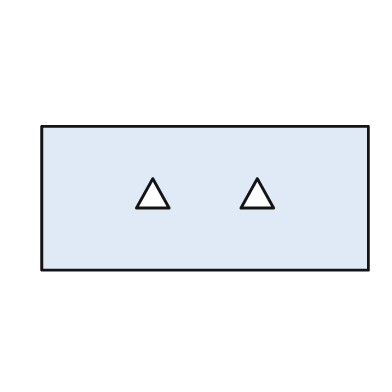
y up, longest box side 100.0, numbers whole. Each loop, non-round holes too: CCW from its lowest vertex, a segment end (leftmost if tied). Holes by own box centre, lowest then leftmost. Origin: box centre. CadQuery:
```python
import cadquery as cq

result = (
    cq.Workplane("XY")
    .moveTo(-50.0, -22.0)
    .lineTo(50.0, -22.0)
    .lineTo(50.0, 22.0)
    .lineTo(-50.0, 22.0)
    .close()
    .moveTo(-21.0, -3.0)
    .lineTo(-11.0, -3.0)
    .lineTo(-16.0, 6.0)
    .close()
    .moveTo(11.0, -3.0)
    .lineTo(21.0, -3.0)
    .lineTo(16.0, 6.0)
    .close()
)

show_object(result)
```